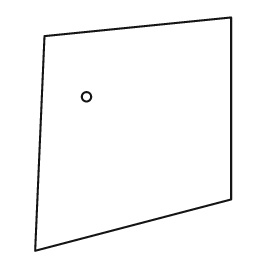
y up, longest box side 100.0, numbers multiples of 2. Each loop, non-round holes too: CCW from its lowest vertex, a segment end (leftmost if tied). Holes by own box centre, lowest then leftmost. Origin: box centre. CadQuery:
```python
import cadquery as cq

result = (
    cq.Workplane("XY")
    .moveTo(-42.0, -50.0)
    .lineTo(42.0, -28.0)
    .lineTo(42.0, 50.0)
    .lineTo(-38.0, 42.0)
    .close()
    .moveTo(-20.0, 16.0)
    .circle(2.0)
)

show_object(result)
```